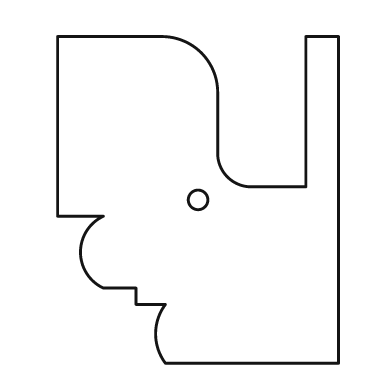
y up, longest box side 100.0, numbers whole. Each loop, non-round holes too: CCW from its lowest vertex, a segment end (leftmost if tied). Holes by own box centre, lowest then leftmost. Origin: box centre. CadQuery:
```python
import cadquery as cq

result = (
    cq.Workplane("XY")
    .moveTo(-10.0, -50.0)
    .lineTo(43.0, -50.0)
    .lineTo(43.0, 50.0)
    .lineTo(33.0, 50.0)
    .lineTo(33.0, 4.0)
    .lineTo(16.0, 4.0)
    .threePointArc((9.0, 7.0), (6.0, 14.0))
    .lineTo(6.0, 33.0)
    .threePointArc((1.0, 45.0), (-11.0, 50.0))
    .lineTo(-43.0, 50.0)
    .lineTo(-43.0, -5.0)
    .lineTo(-29.0, -5.0)
    .threePointArc((-36.0, -16.0), (-29.0, -27.0))
    .lineTo(-19.0, -27.0)
    .lineTo(-19.0, -32.0)
    .lineTo(-10.0, -32.0)
    .threePointArc((-13.0, -41.0), (-10.0, -50.0))
    .close()
    .moveTo(0.0, 0.0)
    .circle(3.0)
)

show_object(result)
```